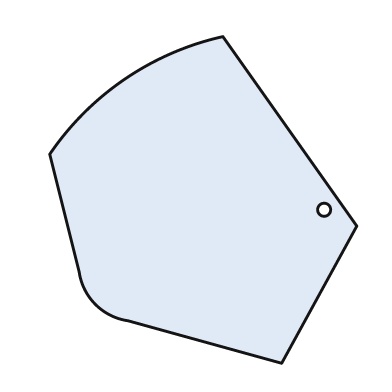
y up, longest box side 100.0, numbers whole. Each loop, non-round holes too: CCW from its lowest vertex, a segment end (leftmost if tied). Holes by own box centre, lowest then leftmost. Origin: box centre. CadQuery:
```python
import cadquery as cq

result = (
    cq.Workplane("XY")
    .moveTo(24.0, -50.0)
    .lineTo(47.0, -8.0)
    .lineTo(6.0, 50.0)
    .threePointArc((-24.0, 37.0), (-47.0, 14.0))
    .lineTo(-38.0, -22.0)
    .threePointArc((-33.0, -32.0), (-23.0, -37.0))
    .close()
    .moveTo(37.0, -3.0)
    .circle(2.0)
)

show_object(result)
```